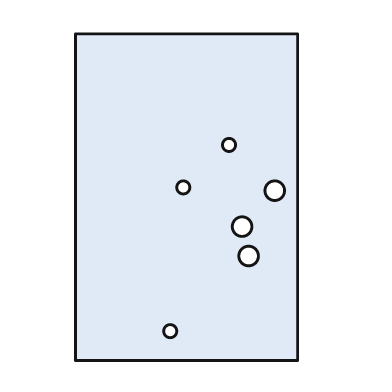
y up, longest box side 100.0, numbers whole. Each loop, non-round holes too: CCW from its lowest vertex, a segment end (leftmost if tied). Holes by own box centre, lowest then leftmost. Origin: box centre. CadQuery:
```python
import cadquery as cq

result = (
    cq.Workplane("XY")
    .moveTo(-34.0, -50.0)
    .lineTo(34.0, -50.0)
    .lineTo(34.0, 50.0)
    .lineTo(-34.0, 50.0)
    .close()
    .moveTo(-5.0, -41.0)
    .circle(2.0)
    .moveTo(19.0, -18.0)
    .circle(3.0)
    .moveTo(17.0, -9.0)
    .circle(3.0)
    .moveTo(27.0, 2.0)
    .circle(3.0)
    .moveTo(-1.0, 3.0)
    .circle(2.0)
    .moveTo(13.0, 16.0)
    .circle(2.0)
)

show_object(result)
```